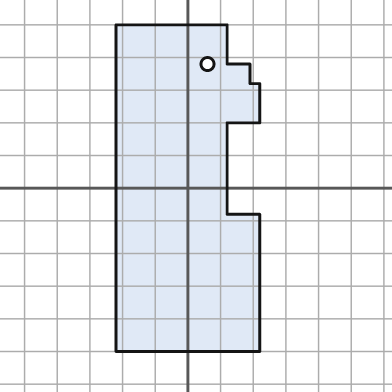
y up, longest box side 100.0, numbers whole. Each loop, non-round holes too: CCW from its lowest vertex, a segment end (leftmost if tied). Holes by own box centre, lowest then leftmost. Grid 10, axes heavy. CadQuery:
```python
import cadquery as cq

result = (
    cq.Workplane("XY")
    .moveTo(-22.0, -50.0)
    .lineTo(22.0, -50.0)
    .lineTo(22.0, -8.0)
    .lineTo(12.0, -8.0)
    .lineTo(12.0, 20.0)
    .lineTo(22.0, 20.0)
    .lineTo(22.0, 32.0)
    .lineTo(19.0, 32.0)
    .lineTo(19.0, 38.0)
    .lineTo(12.0, 38.0)
    .lineTo(12.0, 50.0)
    .lineTo(-22.0, 50.0)
    .close()
    .moveTo(6.0, 38.0)
    .circle(2.0)
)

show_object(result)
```